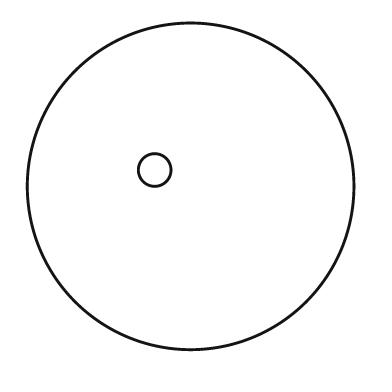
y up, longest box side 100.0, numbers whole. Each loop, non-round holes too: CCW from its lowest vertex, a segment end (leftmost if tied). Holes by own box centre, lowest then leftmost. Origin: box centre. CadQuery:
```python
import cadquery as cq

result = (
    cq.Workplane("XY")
    .moveTo(0.0, 0.0)
    .circle(50.0)
    .moveTo(-11.0, 5.0)
    .circle(5.0)
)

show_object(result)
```